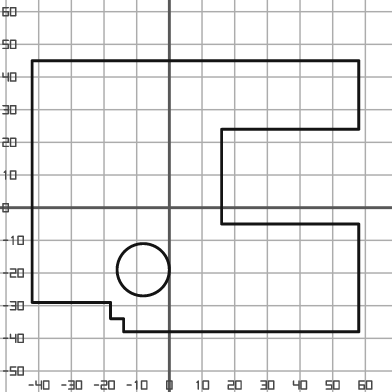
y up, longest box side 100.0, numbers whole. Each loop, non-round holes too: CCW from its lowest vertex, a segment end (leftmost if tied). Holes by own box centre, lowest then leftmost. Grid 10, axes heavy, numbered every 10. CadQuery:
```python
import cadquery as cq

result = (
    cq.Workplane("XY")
    .moveTo(-14.0, -38.0)
    .lineTo(58.0, -38.0)
    .lineTo(58.0, -5.0)
    .lineTo(16.0, -5.0)
    .lineTo(16.0, 24.0)
    .lineTo(58.0, 24.0)
    .lineTo(58.0, 45.0)
    .lineTo(-42.0, 45.0)
    .lineTo(-42.0, -29.0)
    .lineTo(-18.0, -29.0)
    .lineTo(-18.0, -34.0)
    .lineTo(-14.0, -34.0)
    .close()
    .moveTo(-8.0, -19.0)
    .circle(8.0)
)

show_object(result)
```